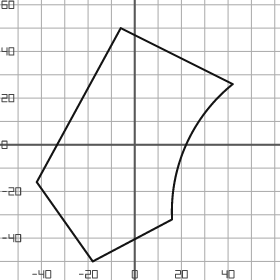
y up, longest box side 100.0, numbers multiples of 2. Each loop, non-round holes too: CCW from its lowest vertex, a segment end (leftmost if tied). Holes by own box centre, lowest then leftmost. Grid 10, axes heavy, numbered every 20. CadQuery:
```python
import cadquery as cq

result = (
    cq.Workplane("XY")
    .moveTo(-18.0, -50.0)
    .lineTo(16.0, -32.0)
    .threePointArc((22.0, 0.0), (42.0, 26.0))
    .lineTo(-6.0, 50.0)
    .lineTo(-42.0, -16.0)
    .close()
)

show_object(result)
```